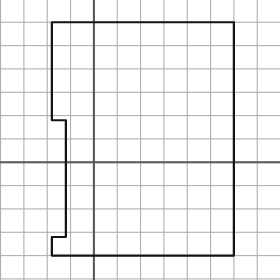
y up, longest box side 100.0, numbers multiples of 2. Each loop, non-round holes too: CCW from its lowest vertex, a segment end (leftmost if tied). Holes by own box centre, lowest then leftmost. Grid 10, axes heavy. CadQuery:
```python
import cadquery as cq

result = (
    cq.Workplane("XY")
    .moveTo(-18.0, -40.0)
    .lineTo(60.0, -40.0)
    .lineTo(60.0, 60.0)
    .lineTo(-18.0, 60.0)
    .lineTo(-18.0, 18.0)
    .lineTo(-12.0, 18.0)
    .lineTo(-12.0, -32.0)
    .lineTo(-18.0, -32.0)
    .close()
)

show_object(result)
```